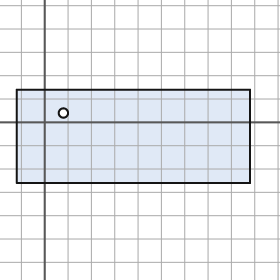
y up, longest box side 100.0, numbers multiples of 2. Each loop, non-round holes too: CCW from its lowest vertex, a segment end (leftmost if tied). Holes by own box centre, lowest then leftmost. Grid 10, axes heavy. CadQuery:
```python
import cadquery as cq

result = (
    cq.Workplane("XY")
    .moveTo(-12.0, -26.0)
    .lineTo(88.0, -26.0)
    .lineTo(88.0, 14.0)
    .lineTo(-12.0, 14.0)
    .close()
    .moveTo(8.0, 4.0)
    .circle(2.0)
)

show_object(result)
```